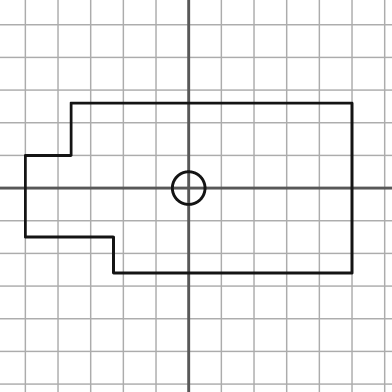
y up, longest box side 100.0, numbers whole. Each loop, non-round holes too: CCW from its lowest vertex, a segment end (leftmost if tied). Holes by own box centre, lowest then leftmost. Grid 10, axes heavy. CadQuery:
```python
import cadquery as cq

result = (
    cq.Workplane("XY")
    .moveTo(-23.0, -26.0)
    .lineTo(50.0, -26.0)
    .lineTo(50.0, 26.0)
    .lineTo(-36.0, 26.0)
    .lineTo(-36.0, 10.0)
    .lineTo(-50.0, 10.0)
    .lineTo(-50.0, -15.0)
    .lineTo(-23.0, -15.0)
    .close()
    .moveTo(0.0, 0.0)
    .circle(5.0)
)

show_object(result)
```